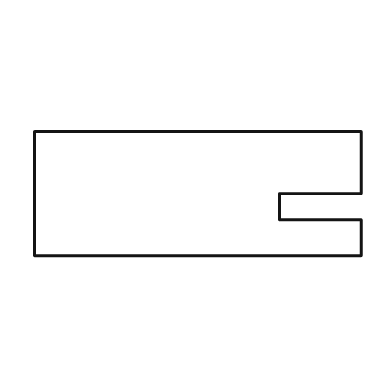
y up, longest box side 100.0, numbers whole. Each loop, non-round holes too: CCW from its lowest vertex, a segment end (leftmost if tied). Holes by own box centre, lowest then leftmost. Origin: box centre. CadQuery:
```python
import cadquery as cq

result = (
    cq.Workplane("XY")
    .moveTo(-50.0, -19.0)
    .lineTo(50.0, -19.0)
    .lineTo(50.0, -8.0)
    .lineTo(25.0, -8.0)
    .lineTo(25.0, 0.0)
    .lineTo(50.0, 0.0)
    .lineTo(50.0, 19.0)
    .lineTo(-50.0, 19.0)
    .close()
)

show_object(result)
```